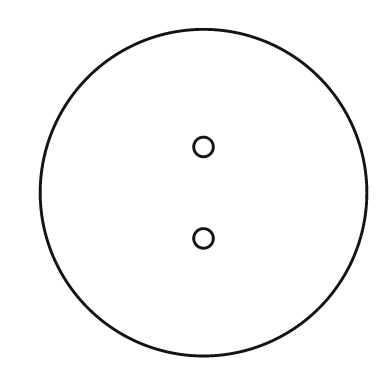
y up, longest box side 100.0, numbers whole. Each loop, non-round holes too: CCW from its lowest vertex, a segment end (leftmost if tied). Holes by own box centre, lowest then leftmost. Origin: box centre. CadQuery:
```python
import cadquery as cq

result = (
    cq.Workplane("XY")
    .moveTo(0.0, 0.0)
    .circle(50.0)
    .moveTo(0.0, -14.0)
    .circle(3.0)
    .moveTo(0.0, 14.0)
    .circle(3.0)
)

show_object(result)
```